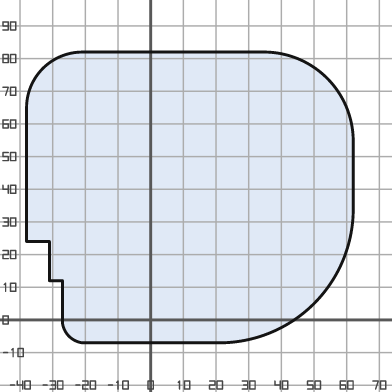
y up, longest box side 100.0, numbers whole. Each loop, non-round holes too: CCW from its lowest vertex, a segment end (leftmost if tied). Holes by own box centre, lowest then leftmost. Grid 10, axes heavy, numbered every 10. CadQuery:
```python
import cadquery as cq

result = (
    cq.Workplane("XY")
    .moveTo(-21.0, -7.0)
    .lineTo(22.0, -7.0)
    .threePointArc((50.0, 5.0), (62.0, 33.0))
    .lineTo(62.0, 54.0)
    .threePointArc((54.0, 74.0), (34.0, 82.0))
    .lineTo(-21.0, 82.0)
    .threePointArc((-33.0, 77.0), (-38.0, 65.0))
    .lineTo(-38.0, 24.0)
    .lineTo(-31.0, 24.0)
    .lineTo(-31.0, 12.0)
    .lineTo(-27.0, 12.0)
    .lineTo(-27.0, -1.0)
    .threePointArc((-25.0, -5.0), (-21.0, -7.0))
    .close()
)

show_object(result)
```